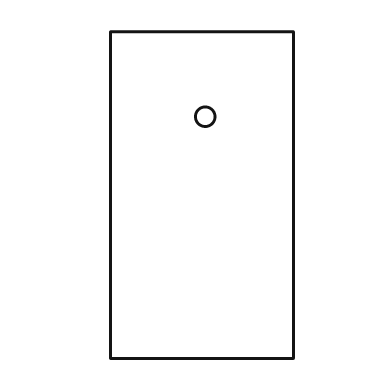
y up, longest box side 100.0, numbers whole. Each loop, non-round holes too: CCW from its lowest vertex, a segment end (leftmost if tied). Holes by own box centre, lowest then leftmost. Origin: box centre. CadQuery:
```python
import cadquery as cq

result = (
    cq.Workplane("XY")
    .moveTo(-28.0, -50.0)
    .lineTo(28.0, -50.0)
    .lineTo(28.0, 50.0)
    .lineTo(-28.0, 50.0)
    .close()
    .moveTo(1.0, 24.0)
    .circle(3.0)
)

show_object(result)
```